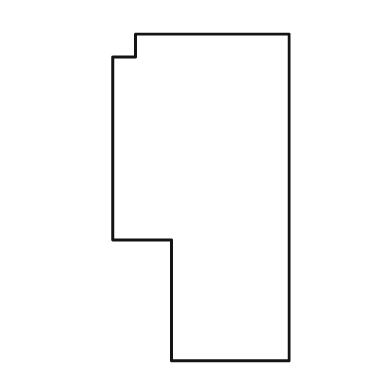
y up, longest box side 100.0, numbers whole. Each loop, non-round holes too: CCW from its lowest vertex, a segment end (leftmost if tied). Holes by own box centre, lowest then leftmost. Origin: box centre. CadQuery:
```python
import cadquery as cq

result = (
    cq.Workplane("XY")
    .moveTo(-9.0, -50.0)
    .lineTo(27.0, -50.0)
    .lineTo(27.0, 50.0)
    .lineTo(-20.0, 50.0)
    .lineTo(-20.0, 43.0)
    .lineTo(-27.0, 43.0)
    .lineTo(-27.0, -13.0)
    .lineTo(-9.0, -13.0)
    .close()
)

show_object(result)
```